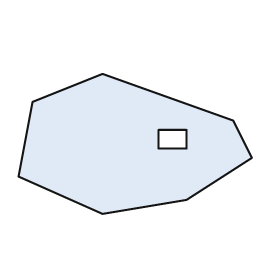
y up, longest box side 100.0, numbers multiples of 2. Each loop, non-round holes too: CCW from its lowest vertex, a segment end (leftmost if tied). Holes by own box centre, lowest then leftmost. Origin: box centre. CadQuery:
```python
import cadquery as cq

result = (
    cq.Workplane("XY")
    .moveTo(-14.0, -30.0)
    .lineTo(22.0, -24.0)
    .lineTo(50.0, -6.0)
    .lineTo(42.0, 10.0)
    .lineTo(-14.0, 30.0)
    .lineTo(-44.0, 18.0)
    .lineTo(-50.0, -14.0)
    .close()
    .moveTo(10.0, -2.0)
    .lineTo(22.0, -2.0)
    .lineTo(22.0, 6.0)
    .lineTo(10.0, 6.0)
    .close()
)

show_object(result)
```